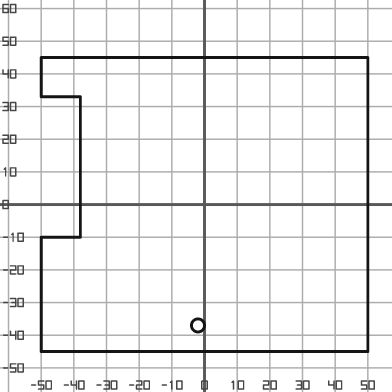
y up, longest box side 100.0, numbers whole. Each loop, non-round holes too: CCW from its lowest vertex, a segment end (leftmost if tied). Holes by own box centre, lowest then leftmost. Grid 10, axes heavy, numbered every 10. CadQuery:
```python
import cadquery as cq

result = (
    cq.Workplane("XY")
    .moveTo(-50.0, -45.0)
    .lineTo(50.0, -45.0)
    .lineTo(50.0, 45.0)
    .lineTo(-50.0, 45.0)
    .lineTo(-50.0, 33.0)
    .lineTo(-38.0, 33.0)
    .lineTo(-38.0, -10.0)
    .lineTo(-50.0, -10.0)
    .close()
    .moveTo(-2.0, -37.0)
    .circle(2.0)
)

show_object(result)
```